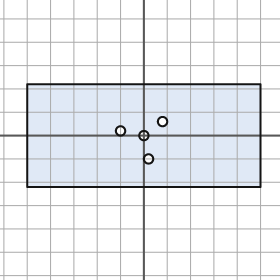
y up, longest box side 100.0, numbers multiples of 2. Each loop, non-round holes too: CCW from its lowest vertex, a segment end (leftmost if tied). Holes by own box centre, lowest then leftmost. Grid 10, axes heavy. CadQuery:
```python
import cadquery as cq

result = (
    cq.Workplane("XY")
    .moveTo(-50.0, -22.0)
    .lineTo(50.0, -22.0)
    .lineTo(50.0, 22.0)
    .lineTo(-50.0, 22.0)
    .close()
    .moveTo(2.0, -10.0)
    .circle(2.0)
    .moveTo(0.0, 0.0)
    .circle(2.0)
    .moveTo(-10.0, 2.0)
    .circle(2.0)
    .moveTo(8.0, 6.0)
    .circle(2.0)
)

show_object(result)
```